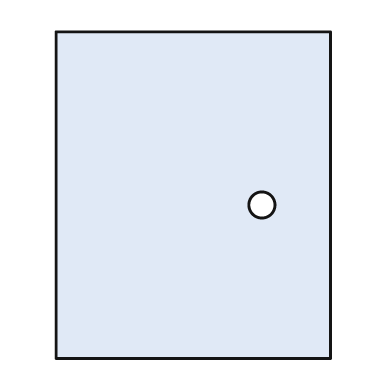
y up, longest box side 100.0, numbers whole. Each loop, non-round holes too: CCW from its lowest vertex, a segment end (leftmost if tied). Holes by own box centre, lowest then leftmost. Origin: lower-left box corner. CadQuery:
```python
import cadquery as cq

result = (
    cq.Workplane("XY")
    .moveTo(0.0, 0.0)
    .lineTo(84.0, 0.0)
    .lineTo(84.0, 100.0)
    .lineTo(0.0, 100.0)
    .close()
    .moveTo(63.0, 47.0)
    .circle(4.0)
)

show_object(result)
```